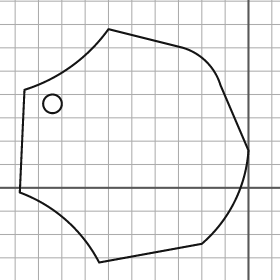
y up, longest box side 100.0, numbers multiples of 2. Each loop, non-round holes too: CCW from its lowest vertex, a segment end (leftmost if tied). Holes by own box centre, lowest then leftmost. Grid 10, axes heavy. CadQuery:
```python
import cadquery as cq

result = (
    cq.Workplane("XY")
    .moveTo(-64.0, -32.0)
    .lineTo(-20.0, -24.0)
    .threePointArc((-6.0, -6.0), (0.0, 16.0))
    .lineTo(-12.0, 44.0)
    .threePointArc((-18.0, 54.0), (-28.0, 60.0))
    .lineTo(-60.0, 68.0)
    .threePointArc((-76.0, 52.0), (-96.0, 42.0))
    .lineTo(-98.0, -2.0)
    .threePointArc((-78.0, -14.0), (-64.0, -32.0))
    .close()
    .moveTo(-84.0, 36.0)
    .circle(4.0)
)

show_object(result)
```